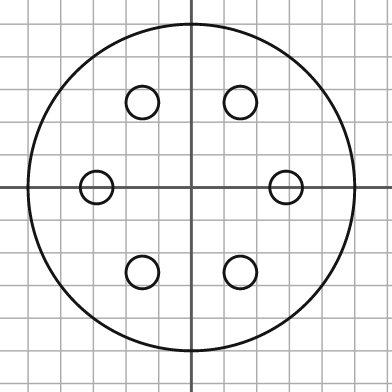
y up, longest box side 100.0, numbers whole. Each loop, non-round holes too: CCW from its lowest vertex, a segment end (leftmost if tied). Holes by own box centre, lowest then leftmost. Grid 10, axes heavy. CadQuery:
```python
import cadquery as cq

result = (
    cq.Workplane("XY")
    .moveTo(0.0, 0.0)
    .circle(50.0)
    .moveTo(-15.0, -26.0)
    .circle(5.0)
    .moveTo(15.0, -26.0)
    .circle(5.0)
    .moveTo(-29.0, 0.0)
    .circle(5.0)
    .moveTo(29.0, 0.0)
    .circle(5.0)
    .moveTo(-15.0, 26.0)
    .circle(5.0)
    .moveTo(15.0, 26.0)
    .circle(5.0)
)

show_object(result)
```